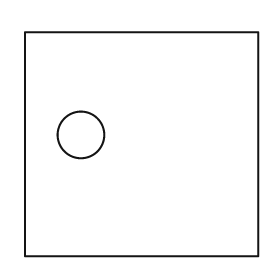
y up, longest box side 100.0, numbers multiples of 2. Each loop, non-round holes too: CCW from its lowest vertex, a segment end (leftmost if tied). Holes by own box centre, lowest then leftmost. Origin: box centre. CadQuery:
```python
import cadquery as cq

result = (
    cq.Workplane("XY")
    .moveTo(-50.0, -48.0)
    .lineTo(50.0, -48.0)
    .lineTo(50.0, 48.0)
    .lineTo(-50.0, 48.0)
    .close()
    .moveTo(-26.0, 4.0)
    .circle(10.0)
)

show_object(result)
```